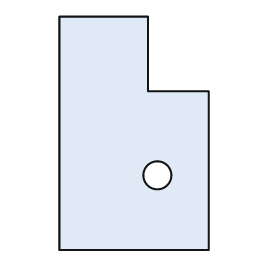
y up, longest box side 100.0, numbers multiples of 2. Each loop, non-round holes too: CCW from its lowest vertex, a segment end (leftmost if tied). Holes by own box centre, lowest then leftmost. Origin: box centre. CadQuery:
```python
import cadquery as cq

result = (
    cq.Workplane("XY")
    .moveTo(-32.0, -50.0)
    .lineTo(32.0, -50.0)
    .lineTo(32.0, 18.0)
    .lineTo(6.0, 18.0)
    .lineTo(6.0, 50.0)
    .lineTo(-32.0, 50.0)
    .close()
    .moveTo(10.0, -18.0)
    .circle(6.0)
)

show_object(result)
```